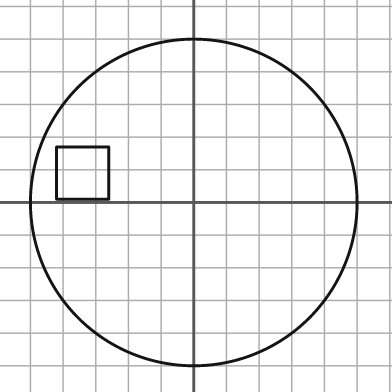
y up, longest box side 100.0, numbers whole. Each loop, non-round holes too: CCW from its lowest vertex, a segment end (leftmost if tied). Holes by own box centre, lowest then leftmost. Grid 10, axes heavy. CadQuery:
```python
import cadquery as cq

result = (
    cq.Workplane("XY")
    .moveTo(0.0, 0.0)
    .circle(50.0)
    .moveTo(-42.0, 1.0)
    .lineTo(-26.0, 1.0)
    .lineTo(-26.0, 17.0)
    .lineTo(-42.0, 17.0)
    .close()
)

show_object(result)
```